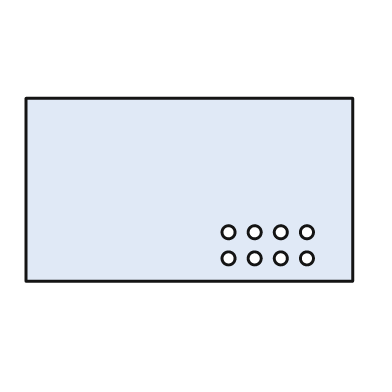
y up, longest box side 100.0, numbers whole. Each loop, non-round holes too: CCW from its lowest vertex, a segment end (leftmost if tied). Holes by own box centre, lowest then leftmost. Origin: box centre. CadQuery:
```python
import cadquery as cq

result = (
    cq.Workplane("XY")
    .moveTo(-50.0, -28.0)
    .lineTo(50.0, -28.0)
    .lineTo(50.0, 28.0)
    .lineTo(-50.0, 28.0)
    .close()
    .moveTo(12.0, -21.0)
    .circle(2.0)
    .moveTo(20.0, -21.0)
    .circle(2.0)
    .moveTo(28.0, -21.0)
    .circle(2.0)
    .moveTo(36.0, -21.0)
    .circle(2.0)
    .moveTo(12.0, -13.0)
    .circle(2.0)
    .moveTo(20.0, -13.0)
    .circle(2.0)
    .moveTo(28.0, -13.0)
    .circle(2.0)
    .moveTo(36.0, -13.0)
    .circle(2.0)
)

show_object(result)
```